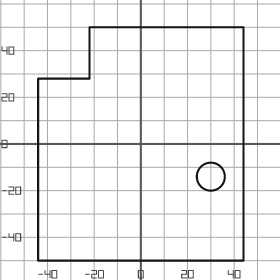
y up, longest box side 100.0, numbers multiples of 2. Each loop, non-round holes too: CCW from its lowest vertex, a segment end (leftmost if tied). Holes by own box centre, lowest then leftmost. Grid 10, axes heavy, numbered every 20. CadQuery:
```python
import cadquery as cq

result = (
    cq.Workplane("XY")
    .moveTo(-44.0, -50.0)
    .lineTo(44.0, -50.0)
    .lineTo(44.0, 50.0)
    .lineTo(-22.0, 50.0)
    .lineTo(-22.0, 28.0)
    .lineTo(-44.0, 28.0)
    .close()
    .moveTo(30.0, -14.0)
    .circle(6.0)
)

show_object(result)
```